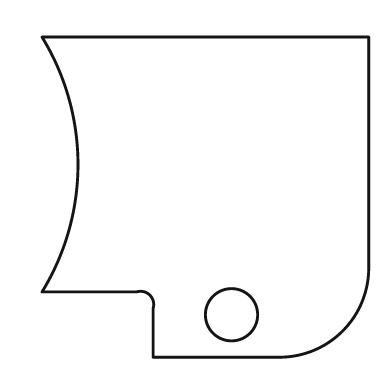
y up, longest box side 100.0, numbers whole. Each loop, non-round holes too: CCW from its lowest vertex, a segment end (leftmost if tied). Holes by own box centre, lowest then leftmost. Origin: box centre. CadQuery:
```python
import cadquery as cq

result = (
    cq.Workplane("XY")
    .moveTo(-16.0, -49.0)
    .lineTo(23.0, -49.0)
    .threePointArc((42.0, -41.0), (50.0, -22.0))
    .lineTo(50.0, 49.0)
    .lineTo(-50.0, 49.0)
    .threePointArc((-39.0, 10.0), (-50.0, -29.0))
    .lineTo(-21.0, -29.0)
    .threePointArc((-17.0, -30.0), (-16.0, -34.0))
    .close()
    .moveTo(8.0, -36.0)
    .circle(8.0)
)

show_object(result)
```